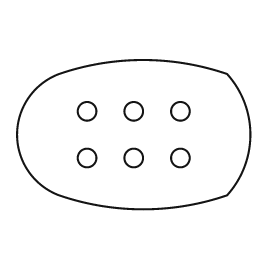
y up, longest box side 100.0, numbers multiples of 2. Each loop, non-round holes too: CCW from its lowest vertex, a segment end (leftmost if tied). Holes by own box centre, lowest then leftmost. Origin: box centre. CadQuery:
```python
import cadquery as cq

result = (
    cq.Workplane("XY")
    .moveTo(-32.0, -26.0)
    .threePointArc((4.0, -32.0), (40.0, -26.0))
    .threePointArc((50.0, 0.0), (40.0, 26.0))
    .threePointArc((4.0, 32.0), (-32.0, 26.0))
    .threePointArc((-50.0, 0.0), (-32.0, -26.0))
    .close()
    .moveTo(-20.0, -10.0)
    .circle(4.0)
    .moveTo(0.0, -10.0)
    .circle(4.0)
    .moveTo(20.0, -10.0)
    .circle(4.0)
    .moveTo(-20.0, 10.0)
    .circle(4.0)
    .moveTo(0.0, 10.0)
    .circle(4.0)
    .moveTo(20.0, 10.0)
    .circle(4.0)
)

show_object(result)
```